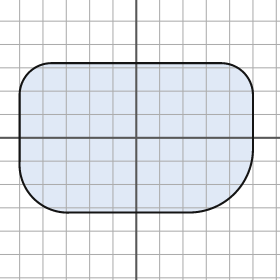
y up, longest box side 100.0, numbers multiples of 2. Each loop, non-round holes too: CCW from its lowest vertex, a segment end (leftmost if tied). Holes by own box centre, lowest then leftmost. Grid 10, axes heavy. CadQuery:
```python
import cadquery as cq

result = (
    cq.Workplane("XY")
    .moveTo(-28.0, -32.0)
    .lineTo(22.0, -32.0)
    .threePointArc((42.0, -24.0), (50.0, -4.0))
    .lineTo(50.0, 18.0)
    .threePointArc((46.0, 28.0), (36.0, 32.0))
    .lineTo(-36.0, 32.0)
    .threePointArc((-46.0, 28.0), (-50.0, 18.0))
    .lineTo(-50.0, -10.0)
    .threePointArc((-44.0, -26.0), (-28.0, -32.0))
    .close()
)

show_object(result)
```